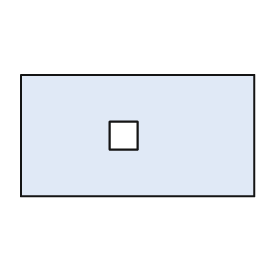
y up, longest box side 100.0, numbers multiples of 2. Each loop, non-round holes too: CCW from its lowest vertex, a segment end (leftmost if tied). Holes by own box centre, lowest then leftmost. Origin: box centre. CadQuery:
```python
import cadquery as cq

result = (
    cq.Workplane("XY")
    .moveTo(-50.0, -26.0)
    .lineTo(50.0, -26.0)
    .lineTo(50.0, 26.0)
    .lineTo(-50.0, 26.0)
    .close()
    .moveTo(-12.0, -6.0)
    .lineTo(0.0, -6.0)
    .lineTo(0.0, 6.0)
    .lineTo(-12.0, 6.0)
    .close()
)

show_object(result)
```